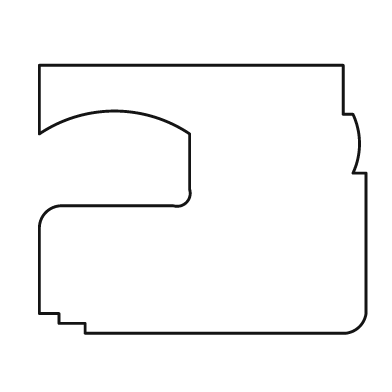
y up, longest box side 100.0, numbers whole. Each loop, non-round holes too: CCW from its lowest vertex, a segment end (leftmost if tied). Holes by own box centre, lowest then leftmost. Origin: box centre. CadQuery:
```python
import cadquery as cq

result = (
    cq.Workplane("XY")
    .moveTo(-36.0, -41.0)
    .lineTo(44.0, -41.0)
    .threePointArc((48.0, -39.0), (50.0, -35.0))
    .lineTo(50.0, 8.0)
    .lineTo(46.0, 8.0)
    .threePointArc((48.0, 17.0), (46.0, 26.0))
    .lineTo(43.0, 26.0)
    .lineTo(43.0, 41.0)
    .lineTo(-50.0, 41.0)
    .lineTo(-50.0, 20.0)
    .threePointArc((-27.0, 27.0), (-4.0, 20.0))
    .lineTo(-4.0, 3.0)
    .threePointArc((-5.0, -1.0), (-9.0, -2.0))
    .lineTo(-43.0, -2.0)
    .threePointArc((-48.0, -4.0), (-50.0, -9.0))
    .lineTo(-50.0, -35.0)
    .lineTo(-44.0, -35.0)
    .lineTo(-44.0, -38.0)
    .lineTo(-36.0, -38.0)
    .close()
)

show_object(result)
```